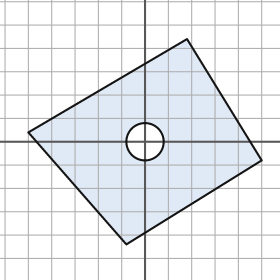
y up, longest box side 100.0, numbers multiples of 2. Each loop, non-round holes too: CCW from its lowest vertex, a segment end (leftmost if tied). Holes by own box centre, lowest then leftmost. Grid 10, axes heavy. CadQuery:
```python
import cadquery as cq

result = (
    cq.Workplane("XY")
    .moveTo(-8.0, -44.0)
    .lineTo(50.0, -8.0)
    .lineTo(18.0, 44.0)
    .lineTo(-50.0, 4.0)
    .close()
    .moveTo(0.0, 0.0)
    .circle(8.0)
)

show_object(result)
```